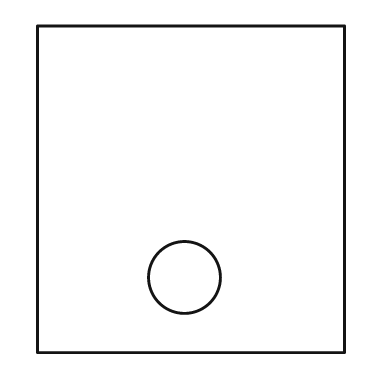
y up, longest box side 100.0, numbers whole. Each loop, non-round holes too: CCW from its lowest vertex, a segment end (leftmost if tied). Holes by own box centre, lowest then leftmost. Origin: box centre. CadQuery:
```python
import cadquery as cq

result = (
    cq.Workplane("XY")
    .moveTo(-47.0, -50.0)
    .lineTo(47.0, -50.0)
    .lineTo(47.0, 50.0)
    .lineTo(-47.0, 50.0)
    .close()
    .moveTo(-2.0, -27.0)
    .circle(11.0)
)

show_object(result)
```